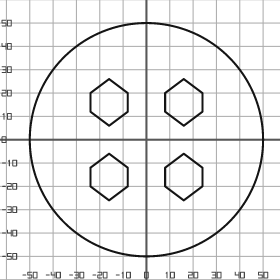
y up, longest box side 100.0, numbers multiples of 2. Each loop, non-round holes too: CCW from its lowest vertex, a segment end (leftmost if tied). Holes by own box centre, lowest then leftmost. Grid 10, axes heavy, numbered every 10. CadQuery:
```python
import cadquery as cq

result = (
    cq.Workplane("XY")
    .moveTo(0.0, 0.0)
    .circle(50.0)
    .moveTo(-16.0, -26.0)
    .lineTo(-8.0, -20.0)
    .lineTo(-8.0, -12.0)
    .lineTo(-16.0, -6.0)
    .lineTo(-24.0, -12.0)
    .lineTo(-24.0, -20.0)
    .close()
    .moveTo(16.0, -26.0)
    .lineTo(24.0, -20.0)
    .lineTo(24.0, -12.0)
    .lineTo(16.0, -6.0)
    .lineTo(8.0, -12.0)
    .lineTo(8.0, -20.0)
    .close()
    .moveTo(-16.0, 6.0)
    .lineTo(-8.0, 12.0)
    .lineTo(-8.0, 20.0)
    .lineTo(-16.0, 26.0)
    .lineTo(-24.0, 20.0)
    .lineTo(-24.0, 12.0)
    .close()
    .moveTo(16.0, 6.0)
    .lineTo(24.0, 12.0)
    .lineTo(24.0, 20.0)
    .lineTo(16.0, 26.0)
    .lineTo(8.0, 20.0)
    .lineTo(8.0, 12.0)
    .close()
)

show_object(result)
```